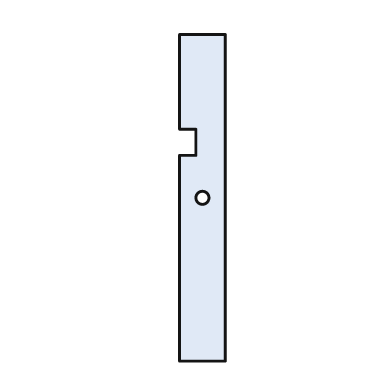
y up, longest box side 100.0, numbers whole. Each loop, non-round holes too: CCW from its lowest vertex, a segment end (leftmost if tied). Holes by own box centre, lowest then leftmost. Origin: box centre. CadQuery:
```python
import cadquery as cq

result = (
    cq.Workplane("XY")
    .moveTo(-7.0, -50.0)
    .lineTo(7.0, -50.0)
    .lineTo(7.0, 50.0)
    .lineTo(-7.0, 50.0)
    .lineTo(-7.0, 21.0)
    .lineTo(-2.0, 21.0)
    .lineTo(-2.0, 13.0)
    .lineTo(-7.0, 13.0)
    .close()
    .moveTo(0.0, 0.0)
    .circle(2.0)
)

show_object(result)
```